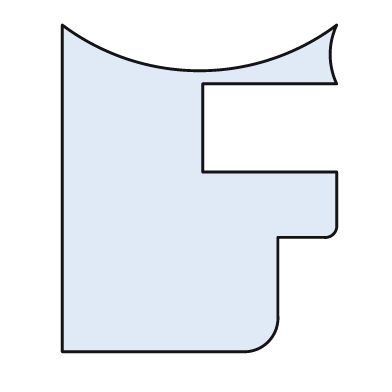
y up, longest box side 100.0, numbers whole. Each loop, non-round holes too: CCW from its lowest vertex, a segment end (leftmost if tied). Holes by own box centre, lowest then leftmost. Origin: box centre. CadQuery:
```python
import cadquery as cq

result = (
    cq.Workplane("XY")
    .moveTo(-42.0, -50.0)
    .lineTo(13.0, -50.0)
    .threePointArc((21.0, -47.0), (24.0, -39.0))
    .lineTo(24.0, -15.0)
    .lineTo(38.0, -15.0)
    .threePointArc((41.0, -14.0), (42.0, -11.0))
    .lineTo(42.0, 5.0)
    .lineTo(1.0, 5.0)
    .lineTo(1.0, 32.0)
    .lineTo(42.0, 32.0)
    .threePointArc((40.0, 41.0), (42.0, 50.0))
    .threePointArc((0.0, 36.0), (-42.0, 50.0))
    .close()
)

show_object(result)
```